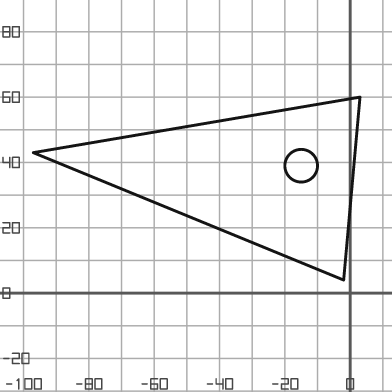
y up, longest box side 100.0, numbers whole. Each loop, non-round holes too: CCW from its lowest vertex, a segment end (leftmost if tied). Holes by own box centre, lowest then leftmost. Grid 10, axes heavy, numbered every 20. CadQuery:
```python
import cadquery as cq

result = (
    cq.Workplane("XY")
    .moveTo(-2.0, 4.0)
    .lineTo(3.0, 60.0)
    .lineTo(-97.0, 43.0)
    .close()
    .moveTo(-15.0, 39.0)
    .circle(5.0)
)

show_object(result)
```